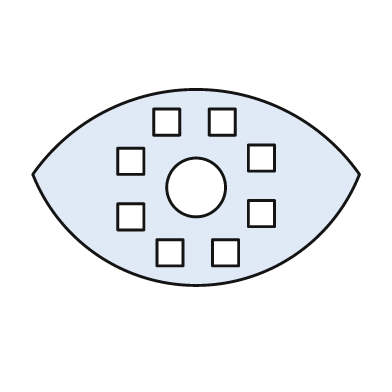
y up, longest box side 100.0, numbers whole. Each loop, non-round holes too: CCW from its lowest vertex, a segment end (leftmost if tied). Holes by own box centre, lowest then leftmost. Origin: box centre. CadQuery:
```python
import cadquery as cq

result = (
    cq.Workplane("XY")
    .moveTo(-50.0, 4.0)
    .threePointArc((0.0, -30.0), (50.0, 4.0))
    .threePointArc((0.0, 30.0), (-50.0, 4.0))
    .close()
    .moveTo(-12.0, -24.0)
    .lineTo(-4.0, -24.0)
    .lineTo(-4.0, -16.0)
    .lineTo(-12.0, -16.0)
    .close()
    .moveTo(5.0, -24.0)
    .lineTo(13.0, -24.0)
    .lineTo(13.0, -16.0)
    .lineTo(5.0, -16.0)
    .close()
    .moveTo(-24.0, -13.0)
    .lineTo(-16.0, -13.0)
    .lineTo(-16.0, -5.0)
    .lineTo(-24.0, -5.0)
    .close()
    .moveTo(16.0, -12.0)
    .lineTo(24.0, -12.0)
    .lineTo(24.0, -4.0)
    .lineTo(16.0, -4.0)
    .close()
    .moveTo(0.0, 0.0)
    .circle(9.0)
    .moveTo(-24.0, 4.0)
    .lineTo(-16.0, 4.0)
    .lineTo(-16.0, 12.0)
    .lineTo(-24.0, 12.0)
    .close()
    .moveTo(16.0, 5.0)
    .lineTo(24.0, 5.0)
    .lineTo(24.0, 13.0)
    .lineTo(16.0, 13.0)
    .close()
    .moveTo(-13.0, 16.0)
    .lineTo(-5.0, 16.0)
    .lineTo(-5.0, 24.0)
    .lineTo(-13.0, 24.0)
    .close()
    .moveTo(4.0, 16.0)
    .lineTo(12.0, 16.0)
    .lineTo(12.0, 24.0)
    .lineTo(4.0, 24.0)
    .close()
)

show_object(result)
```